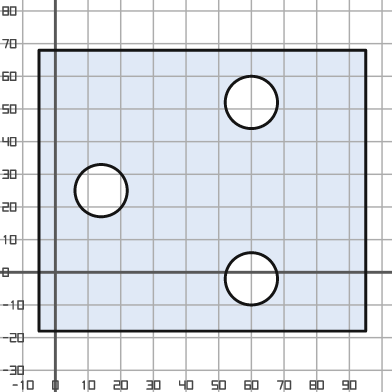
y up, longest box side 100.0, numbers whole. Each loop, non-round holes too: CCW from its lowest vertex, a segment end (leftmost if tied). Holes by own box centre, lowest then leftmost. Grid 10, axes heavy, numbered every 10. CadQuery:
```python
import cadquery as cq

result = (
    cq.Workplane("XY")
    .moveTo(-5.0, -18.0)
    .lineTo(95.0, -18.0)
    .lineTo(95.0, 68.0)
    .lineTo(-5.0, 68.0)
    .close()
    .moveTo(60.0, -2.0)
    .circle(8.0)
    .moveTo(14.0, 25.0)
    .circle(8.0)
    .moveTo(60.0, 52.0)
    .circle(8.0)
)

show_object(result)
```